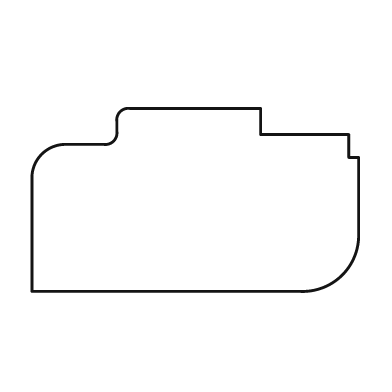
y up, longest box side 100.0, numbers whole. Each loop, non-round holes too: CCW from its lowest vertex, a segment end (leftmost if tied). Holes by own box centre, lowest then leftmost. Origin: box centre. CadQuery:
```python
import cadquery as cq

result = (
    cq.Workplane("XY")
    .moveTo(-50.0, -28.0)
    .lineTo(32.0, -28.0)
    .threePointArc((45.0, -23.0), (50.0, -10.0))
    .lineTo(50.0, 13.0)
    .lineTo(47.0, 13.0)
    .lineTo(47.0, 20.0)
    .lineTo(20.0, 20.0)
    .lineTo(20.0, 28.0)
    .lineTo(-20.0, 28.0)
    .threePointArc((-23.0, 27.0), (-24.0, 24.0))
    .lineTo(-24.0, 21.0)
    .threePointArc((-25.0, 18.0), (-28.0, 17.0))
    .lineTo(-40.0, 17.0)
    .threePointArc((-47.0, 14.0), (-50.0, 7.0))
    .close()
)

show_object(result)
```